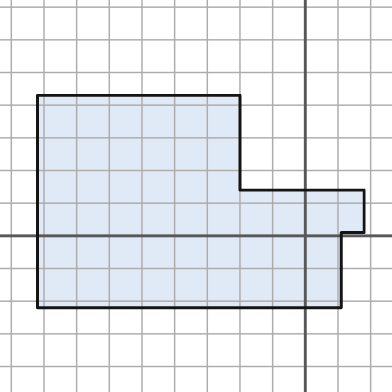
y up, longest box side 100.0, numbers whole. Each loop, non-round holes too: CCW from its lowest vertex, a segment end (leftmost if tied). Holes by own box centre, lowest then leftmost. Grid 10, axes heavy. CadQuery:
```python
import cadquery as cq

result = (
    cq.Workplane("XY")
    .moveTo(-82.0, -22.0)
    .lineTo(11.0, -22.0)
    .lineTo(11.0, 1.0)
    .lineTo(18.0, 1.0)
    .lineTo(18.0, 14.0)
    .lineTo(-20.0, 14.0)
    .lineTo(-20.0, 43.0)
    .lineTo(-82.0, 43.0)
    .close()
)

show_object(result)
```